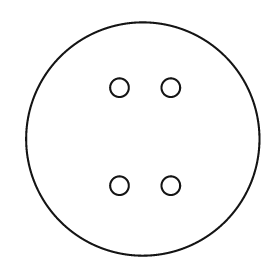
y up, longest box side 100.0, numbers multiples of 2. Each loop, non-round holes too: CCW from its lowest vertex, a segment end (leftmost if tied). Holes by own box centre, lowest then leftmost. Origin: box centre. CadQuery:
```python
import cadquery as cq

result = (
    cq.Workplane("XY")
    .moveTo(0.0, 0.0)
    .circle(50.0)
    .moveTo(-10.0, -20.0)
    .circle(4.0)
    .moveTo(12.0, -20.0)
    .circle(4.0)
    .moveTo(-10.0, 22.0)
    .circle(4.0)
    .moveTo(12.0, 22.0)
    .circle(4.0)
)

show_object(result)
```